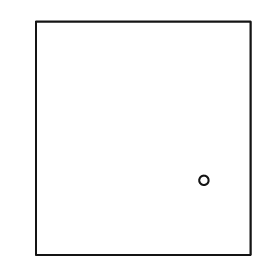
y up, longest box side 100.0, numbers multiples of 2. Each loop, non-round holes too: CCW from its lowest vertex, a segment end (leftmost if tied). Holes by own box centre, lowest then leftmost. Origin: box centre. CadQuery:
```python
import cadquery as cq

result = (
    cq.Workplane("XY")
    .moveTo(-46.0, -50.0)
    .lineTo(46.0, -50.0)
    .lineTo(46.0, 50.0)
    .lineTo(-46.0, 50.0)
    .close()
    .moveTo(26.0, -18.0)
    .circle(2.0)
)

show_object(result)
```